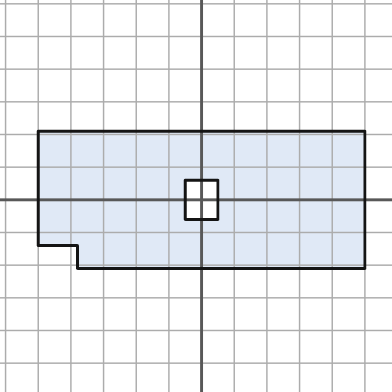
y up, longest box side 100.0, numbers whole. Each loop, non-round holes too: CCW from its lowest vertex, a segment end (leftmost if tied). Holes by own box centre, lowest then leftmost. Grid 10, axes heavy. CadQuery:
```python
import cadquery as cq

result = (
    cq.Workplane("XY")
    .moveTo(-38.0, -21.0)
    .lineTo(50.0, -21.0)
    .lineTo(50.0, 21.0)
    .lineTo(-50.0, 21.0)
    .lineTo(-50.0, -14.0)
    .lineTo(-38.0, -14.0)
    .close()
    .moveTo(-5.0, -6.0)
    .lineTo(5.0, -6.0)
    .lineTo(5.0, 6.0)
    .lineTo(-5.0, 6.0)
    .close()
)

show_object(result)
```